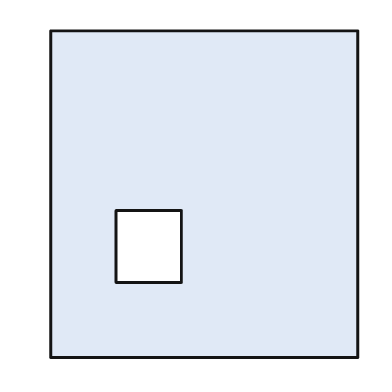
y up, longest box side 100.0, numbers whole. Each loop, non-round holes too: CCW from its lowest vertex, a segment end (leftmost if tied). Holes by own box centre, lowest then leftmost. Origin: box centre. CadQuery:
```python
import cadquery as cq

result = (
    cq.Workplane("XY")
    .moveTo(-47.0, -50.0)
    .lineTo(47.0, -50.0)
    .lineTo(47.0, 50.0)
    .lineTo(-47.0, 50.0)
    .close()
    .moveTo(-27.0, -27.0)
    .lineTo(-7.0, -27.0)
    .lineTo(-7.0, -5.0)
    .lineTo(-27.0, -5.0)
    .close()
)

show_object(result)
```